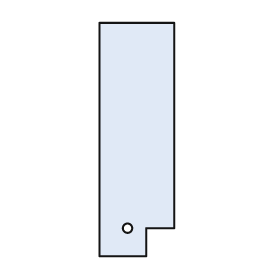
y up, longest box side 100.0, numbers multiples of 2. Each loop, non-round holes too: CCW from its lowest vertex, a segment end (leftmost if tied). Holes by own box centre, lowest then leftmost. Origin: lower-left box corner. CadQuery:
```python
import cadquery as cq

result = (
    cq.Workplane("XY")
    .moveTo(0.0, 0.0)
    .lineTo(20.0, 0.0)
    .lineTo(20.0, 12.0)
    .lineTo(32.0, 12.0)
    .lineTo(32.0, 100.0)
    .lineTo(0.0, 100.0)
    .close()
    .moveTo(12.0, 12.0)
    .circle(2.0)
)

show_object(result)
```